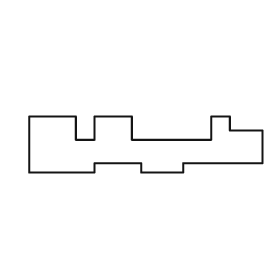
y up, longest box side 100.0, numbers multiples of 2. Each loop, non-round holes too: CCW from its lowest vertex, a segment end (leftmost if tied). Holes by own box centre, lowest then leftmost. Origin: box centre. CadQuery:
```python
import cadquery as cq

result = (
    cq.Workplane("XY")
    .moveTo(-50.0, -12.0)
    .lineTo(-22.0, -12.0)
    .lineTo(-22.0, -8.0)
    .lineTo(-2.0, -8.0)
    .lineTo(-2.0, -12.0)
    .lineTo(16.0, -12.0)
    .lineTo(16.0, -8.0)
    .lineTo(50.0, -8.0)
    .lineTo(50.0, 6.0)
    .lineTo(36.0, 6.0)
    .lineTo(36.0, 12.0)
    .lineTo(28.0, 12.0)
    .lineTo(28.0, 2.0)
    .lineTo(-6.0, 2.0)
    .lineTo(-6.0, 12.0)
    .lineTo(-22.0, 12.0)
    .lineTo(-22.0, 2.0)
    .lineTo(-30.0, 2.0)
    .lineTo(-30.0, 12.0)
    .lineTo(-50.0, 12.0)
    .close()
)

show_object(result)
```